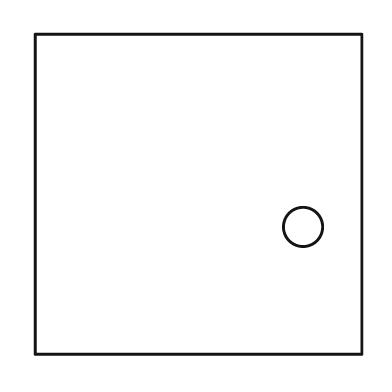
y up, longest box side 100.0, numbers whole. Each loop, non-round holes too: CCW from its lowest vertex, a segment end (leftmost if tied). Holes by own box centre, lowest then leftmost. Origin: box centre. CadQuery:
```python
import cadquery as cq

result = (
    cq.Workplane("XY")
    .moveTo(-50.0, -49.0)
    .lineTo(50.0, -49.0)
    .lineTo(50.0, 49.0)
    .lineTo(-50.0, 49.0)
    .close()
    .moveTo(32.0, -10.0)
    .circle(6.0)
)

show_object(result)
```